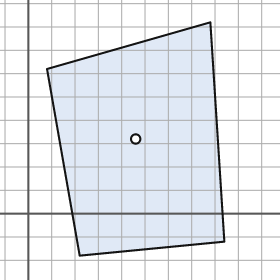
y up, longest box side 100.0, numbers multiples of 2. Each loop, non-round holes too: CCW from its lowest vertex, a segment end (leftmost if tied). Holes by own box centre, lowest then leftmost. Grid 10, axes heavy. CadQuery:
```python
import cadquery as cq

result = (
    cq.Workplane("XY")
    .moveTo(22.0, -18.0)
    .lineTo(84.0, -12.0)
    .lineTo(78.0, 82.0)
    .lineTo(8.0, 62.0)
    .close()
    .moveTo(46.0, 32.0)
    .circle(2.0)
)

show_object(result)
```